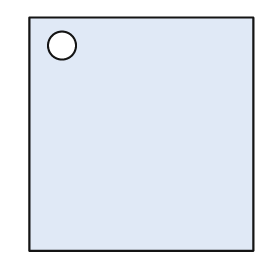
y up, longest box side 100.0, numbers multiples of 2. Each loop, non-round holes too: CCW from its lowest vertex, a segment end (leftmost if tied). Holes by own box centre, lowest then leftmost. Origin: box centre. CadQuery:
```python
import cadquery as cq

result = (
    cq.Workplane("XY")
    .moveTo(-48.0, -50.0)
    .lineTo(48.0, -50.0)
    .lineTo(48.0, 50.0)
    .lineTo(-48.0, 50.0)
    .close()
    .moveTo(-34.0, 38.0)
    .circle(6.0)
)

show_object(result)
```